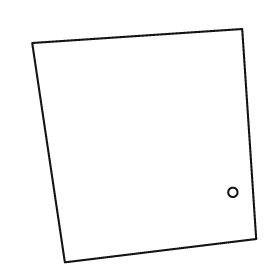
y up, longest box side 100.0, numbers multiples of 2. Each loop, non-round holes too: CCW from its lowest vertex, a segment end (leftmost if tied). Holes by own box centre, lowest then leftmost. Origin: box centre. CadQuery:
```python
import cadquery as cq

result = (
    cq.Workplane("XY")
    .moveTo(-34.0, -50.0)
    .lineTo(48.0, -40.0)
    .lineTo(42.0, 50.0)
    .lineTo(-48.0, 44.0)
    .close()
    .moveTo(38.0, -20.0)
    .circle(2.0)
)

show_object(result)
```